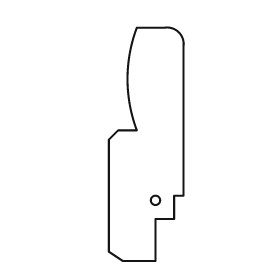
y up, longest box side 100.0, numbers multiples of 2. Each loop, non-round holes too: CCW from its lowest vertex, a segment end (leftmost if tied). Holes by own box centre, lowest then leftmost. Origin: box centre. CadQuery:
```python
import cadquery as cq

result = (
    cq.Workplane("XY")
    .moveTo(-10.0, -50.0)
    .lineTo(4.0, -50.0)
    .lineTo(4.0, -32.0)
    .lineTo(12.0, -32.0)
    .lineTo(12.0, -22.0)
    .lineTo(16.0, -22.0)
    .lineTo(16.0, 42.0)
    .threePointArc((14.0, 48.0), (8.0, 50.0))
    .lineTo(-4.0, 50.0)
    .threePointArc((-8.0, 28.0), (-4.0, 6.0))
    .lineTo(-12.0, 6.0)
    .lineTo(-16.0, 2.0)
    .lineTo(-16.0, -46.0)
    .close()
    .moveTo(4.0, -24.0)
    .circle(2.0)
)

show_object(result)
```